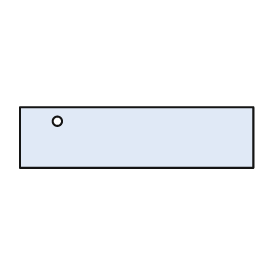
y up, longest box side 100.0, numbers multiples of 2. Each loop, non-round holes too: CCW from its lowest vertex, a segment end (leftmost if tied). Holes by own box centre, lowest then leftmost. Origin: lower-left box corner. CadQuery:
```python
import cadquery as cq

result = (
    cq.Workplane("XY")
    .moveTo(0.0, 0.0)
    .lineTo(100.0, 0.0)
    .lineTo(100.0, 26.0)
    .lineTo(0.0, 26.0)
    .close()
    .moveTo(16.0, 20.0)
    .circle(2.0)
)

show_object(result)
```